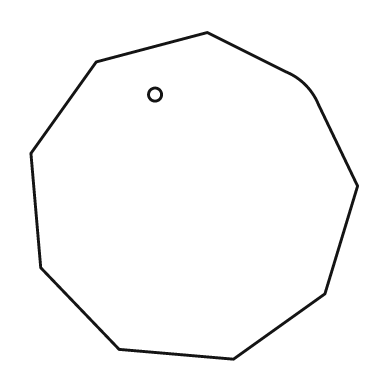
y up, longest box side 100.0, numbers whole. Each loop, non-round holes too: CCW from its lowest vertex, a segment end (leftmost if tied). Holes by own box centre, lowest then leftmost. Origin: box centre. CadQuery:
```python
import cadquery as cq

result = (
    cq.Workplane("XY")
    .moveTo(12.0, -50.0)
    .lineTo(40.0, -30.0)
    .lineTo(50.0, 3.0)
    .lineTo(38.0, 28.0)
    .threePointArc((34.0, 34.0), (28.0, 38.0))
    .lineTo(4.0, 50.0)
    .lineTo(-30.0, 41.0)
    .lineTo(-50.0, 13.0)
    .lineTo(-47.0, -22.0)
    .lineTo(-23.0, -47.0)
    .close()
    .moveTo(-12.0, 31.0)
    .circle(2.0)
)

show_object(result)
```